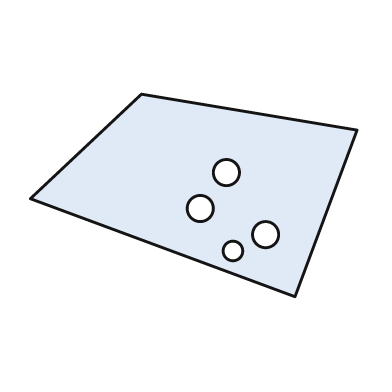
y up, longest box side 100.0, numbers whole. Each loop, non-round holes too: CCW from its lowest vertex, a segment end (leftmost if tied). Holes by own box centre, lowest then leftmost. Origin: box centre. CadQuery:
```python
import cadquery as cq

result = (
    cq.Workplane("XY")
    .moveTo(31.0, -31.0)
    .lineTo(50.0, 20.0)
    .lineTo(-16.0, 31.0)
    .lineTo(-50.0, -1.0)
    .close()
    .moveTo(12.0, -17.0)
    .circle(3.0)
    .moveTo(22.0, -12.0)
    .circle(4.0)
    .moveTo(2.0, -4.0)
    .circle(4.0)
    .moveTo(10.0, 7.0)
    .circle(4.0)
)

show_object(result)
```